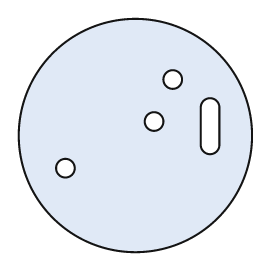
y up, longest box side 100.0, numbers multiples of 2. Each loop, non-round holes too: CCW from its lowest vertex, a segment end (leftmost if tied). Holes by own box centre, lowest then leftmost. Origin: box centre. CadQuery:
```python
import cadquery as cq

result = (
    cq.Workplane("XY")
    .moveTo(0.0, 0.0)
    .circle(50.0)
    .moveTo(-30.0, -14.0)
    .circle(4.0)
    .moveTo(28.0, -4.0)
    .threePointArc((32.0, -8.0), (36.0, -4.0))
    .lineTo(36.0, 12.0)
    .threePointArc((32.0, 16.0), (28.0, 12.0))
    .close()
    .moveTo(8.0, 6.0)
    .circle(4.0)
    .moveTo(16.0, 24.0)
    .circle(4.0)
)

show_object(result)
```